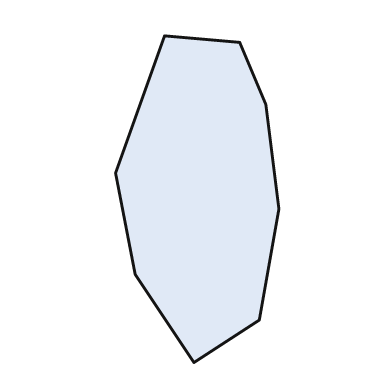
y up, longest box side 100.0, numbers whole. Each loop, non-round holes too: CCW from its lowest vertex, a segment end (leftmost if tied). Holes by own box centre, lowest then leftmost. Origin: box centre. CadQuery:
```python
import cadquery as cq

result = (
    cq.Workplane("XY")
    .moveTo(-1.0, -50.0)
    .lineTo(19.0, -37.0)
    .lineTo(25.0, -3.0)
    .lineTo(21.0, 29.0)
    .lineTo(13.0, 48.0)
    .lineTo(-10.0, 50.0)
    .lineTo(-25.0, 8.0)
    .lineTo(-19.0, -23.0)
    .close()
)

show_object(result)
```